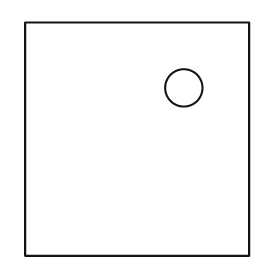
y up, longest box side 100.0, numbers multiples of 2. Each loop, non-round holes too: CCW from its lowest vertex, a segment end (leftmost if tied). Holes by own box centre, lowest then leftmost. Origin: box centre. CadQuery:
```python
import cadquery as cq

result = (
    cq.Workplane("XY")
    .moveTo(-48.0, -50.0)
    .lineTo(48.0, -50.0)
    .lineTo(48.0, 50.0)
    .lineTo(-48.0, 50.0)
    .close()
    .moveTo(20.0, 22.0)
    .circle(8.0)
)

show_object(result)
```